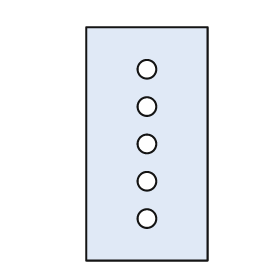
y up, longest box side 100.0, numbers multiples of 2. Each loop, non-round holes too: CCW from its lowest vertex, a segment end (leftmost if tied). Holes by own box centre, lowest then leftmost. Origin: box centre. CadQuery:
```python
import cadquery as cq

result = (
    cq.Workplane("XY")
    .moveTo(-26.0, -50.0)
    .lineTo(26.0, -50.0)
    .lineTo(26.0, 50.0)
    .lineTo(-26.0, 50.0)
    .close()
    .moveTo(0.0, -32.0)
    .circle(4.0)
    .moveTo(0.0, -16.0)
    .circle(4.0)
    .moveTo(0.0, 0.0)
    .circle(4.0)
    .moveTo(0.0, 16.0)
    .circle(4.0)
    .moveTo(0.0, 32.0)
    .circle(4.0)
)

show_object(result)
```